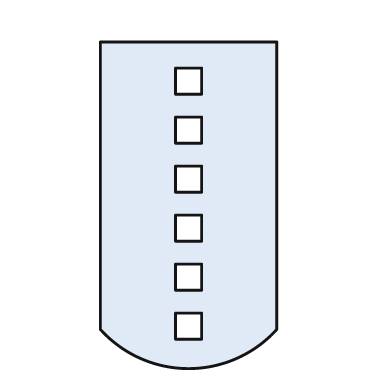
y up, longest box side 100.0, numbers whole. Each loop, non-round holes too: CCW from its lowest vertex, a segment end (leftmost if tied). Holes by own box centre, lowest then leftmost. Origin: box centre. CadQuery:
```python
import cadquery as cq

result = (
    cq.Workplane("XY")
    .moveTo(-27.0, -38.0)
    .threePointArc((0.0, -50.0), (27.0, -38.0))
    .lineTo(27.0, 50.0)
    .lineTo(-27.0, 50.0)
    .close()
    .moveTo(-4.0, -41.0)
    .lineTo(4.0, -41.0)
    .lineTo(4.0, -33.0)
    .lineTo(-4.0, -33.0)
    .close()
    .moveTo(-4.0, -26.0)
    .lineTo(4.0, -26.0)
    .lineTo(4.0, -18.0)
    .lineTo(-4.0, -18.0)
    .close()
    .moveTo(-4.0, -11.0)
    .lineTo(4.0, -11.0)
    .lineTo(4.0, -3.0)
    .lineTo(-4.0, -3.0)
    .close()
    .moveTo(-4.0, 4.0)
    .lineTo(4.0, 4.0)
    .lineTo(4.0, 12.0)
    .lineTo(-4.0, 12.0)
    .close()
    .moveTo(-4.0, 19.0)
    .lineTo(4.0, 19.0)
    .lineTo(4.0, 27.0)
    .lineTo(-4.0, 27.0)
    .close()
    .moveTo(-4.0, 34.0)
    .lineTo(4.0, 34.0)
    .lineTo(4.0, 42.0)
    .lineTo(-4.0, 42.0)
    .close()
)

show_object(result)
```